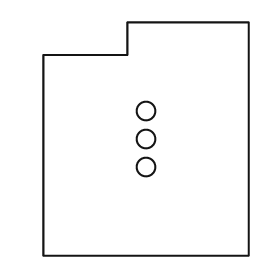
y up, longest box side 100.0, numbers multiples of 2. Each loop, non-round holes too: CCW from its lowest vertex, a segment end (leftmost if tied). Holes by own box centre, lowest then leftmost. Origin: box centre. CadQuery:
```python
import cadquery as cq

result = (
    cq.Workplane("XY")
    .moveTo(-44.0, -50.0)
    .lineTo(44.0, -50.0)
    .lineTo(44.0, 50.0)
    .lineTo(-8.0, 50.0)
    .lineTo(-8.0, 36.0)
    .lineTo(-44.0, 36.0)
    .close()
    .moveTo(0.0, -12.0)
    .circle(4.0)
    .moveTo(0.0, 0.0)
    .circle(4.0)
    .moveTo(0.0, 12.0)
    .circle(4.0)
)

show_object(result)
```